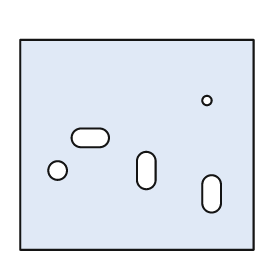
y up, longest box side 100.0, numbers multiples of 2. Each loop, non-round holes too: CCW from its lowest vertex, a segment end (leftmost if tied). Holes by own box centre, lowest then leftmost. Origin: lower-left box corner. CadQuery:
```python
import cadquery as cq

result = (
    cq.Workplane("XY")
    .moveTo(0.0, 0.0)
    .lineTo(100.0, 0.0)
    .lineTo(100.0, 90.0)
    .lineTo(0.0, 90.0)
    .close()
    .moveTo(78.0, 20.0)
    .threePointArc((82.0, 16.0), (86.0, 20.0))
    .lineTo(86.0, 28.0)
    .threePointArc((82.0, 32.0), (78.0, 28.0))
    .close()
    .moveTo(16.0, 34.0)
    .circle(4.0)
    .moveTo(50.0, 30.0)
    .threePointArc((54.0, 26.0), (58.0, 30.0))
    .lineTo(58.0, 38.0)
    .threePointArc((54.0, 42.0), (50.0, 38.0))
    .close()
    .moveTo(26.0, 44.0)
    .lineTo(34.0, 44.0)
    .threePointArc((38.0, 48.0), (34.0, 52.0))
    .lineTo(26.0, 52.0)
    .threePointArc((22.0, 48.0), (26.0, 44.0))
    .close()
    .moveTo(80.0, 64.0)
    .circle(2.0)
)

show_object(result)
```